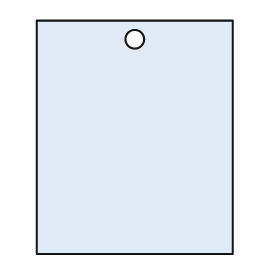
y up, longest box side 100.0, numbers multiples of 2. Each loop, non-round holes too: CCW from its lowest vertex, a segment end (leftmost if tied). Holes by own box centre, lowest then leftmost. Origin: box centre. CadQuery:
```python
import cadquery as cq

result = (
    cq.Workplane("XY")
    .moveTo(-42.0, -50.0)
    .lineTo(42.0, -50.0)
    .lineTo(42.0, 50.0)
    .lineTo(-42.0, 50.0)
    .close()
    .moveTo(0.0, 42.0)
    .circle(4.0)
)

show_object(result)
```